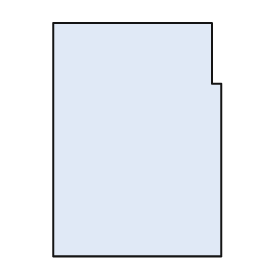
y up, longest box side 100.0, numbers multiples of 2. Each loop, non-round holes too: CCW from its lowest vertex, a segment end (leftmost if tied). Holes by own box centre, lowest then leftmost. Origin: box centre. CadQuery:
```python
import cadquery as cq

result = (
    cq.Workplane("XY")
    .moveTo(-36.0, -50.0)
    .lineTo(36.0, -50.0)
    .lineTo(36.0, 24.0)
    .lineTo(32.0, 24.0)
    .lineTo(32.0, 50.0)
    .lineTo(-36.0, 50.0)
    .close()
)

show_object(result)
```